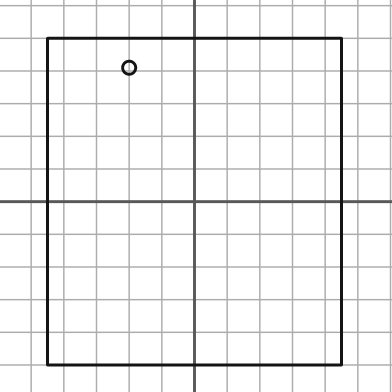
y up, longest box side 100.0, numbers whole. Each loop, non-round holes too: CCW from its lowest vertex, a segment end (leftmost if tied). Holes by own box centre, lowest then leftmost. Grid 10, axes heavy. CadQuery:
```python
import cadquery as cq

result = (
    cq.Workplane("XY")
    .moveTo(-45.0, -50.0)
    .lineTo(45.0, -50.0)
    .lineTo(45.0, 50.0)
    .lineTo(-45.0, 50.0)
    .close()
    .moveTo(-20.0, 41.0)
    .circle(2.0)
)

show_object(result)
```